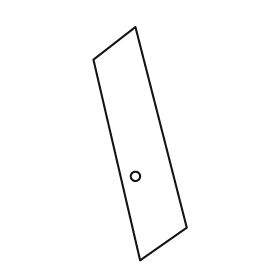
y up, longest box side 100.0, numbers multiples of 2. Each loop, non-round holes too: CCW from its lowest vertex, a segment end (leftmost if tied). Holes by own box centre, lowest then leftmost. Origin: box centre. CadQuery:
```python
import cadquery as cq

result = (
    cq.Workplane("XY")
    .moveTo(0.0, -50.0)
    .lineTo(20.0, -36.0)
    .lineTo(-2.0, 50.0)
    .lineTo(-20.0, 36.0)
    .close()
    .moveTo(-2.0, -14.0)
    .circle(2.0)
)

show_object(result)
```